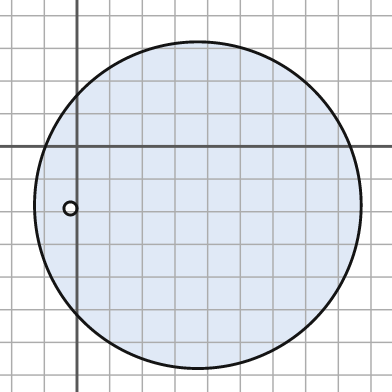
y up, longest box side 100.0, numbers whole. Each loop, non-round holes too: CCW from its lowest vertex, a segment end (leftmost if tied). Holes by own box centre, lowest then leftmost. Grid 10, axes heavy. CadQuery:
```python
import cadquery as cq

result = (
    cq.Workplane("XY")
    .moveTo(37.0, -18.0)
    .circle(50.0)
    .moveTo(-2.0, -19.0)
    .circle(2.0)
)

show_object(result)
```